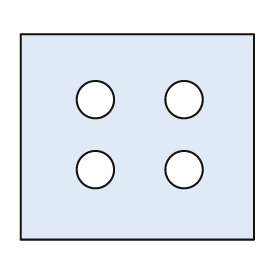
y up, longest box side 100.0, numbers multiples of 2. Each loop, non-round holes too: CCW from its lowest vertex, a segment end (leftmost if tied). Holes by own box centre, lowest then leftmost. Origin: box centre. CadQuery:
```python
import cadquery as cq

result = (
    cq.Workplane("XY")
    .moveTo(-50.0, -44.0)
    .lineTo(50.0, -44.0)
    .lineTo(50.0, 44.0)
    .lineTo(-50.0, 44.0)
    .close()
    .moveTo(-18.0, -14.0)
    .circle(8.0)
    .moveTo(20.0, -14.0)
    .circle(8.0)
    .moveTo(-18.0, 16.0)
    .circle(8.0)
    .moveTo(20.0, 16.0)
    .circle(8.0)
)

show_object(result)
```